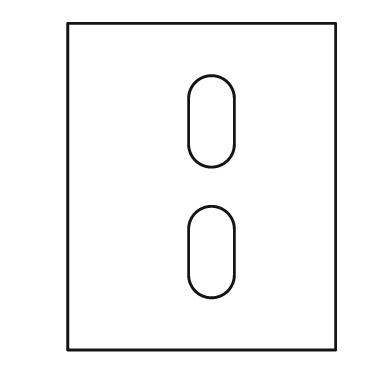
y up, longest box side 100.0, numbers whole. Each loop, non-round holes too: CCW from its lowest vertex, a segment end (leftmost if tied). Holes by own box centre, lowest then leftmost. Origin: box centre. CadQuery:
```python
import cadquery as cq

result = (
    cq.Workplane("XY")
    .moveTo(-41.0, -50.0)
    .lineTo(41.0, -50.0)
    .lineTo(41.0, 50.0)
    .lineTo(-41.0, 50.0)
    .close()
    .moveTo(-4.0, -27.0)
    .threePointArc((3.0, -34.0), (10.0, -27.0))
    .lineTo(10.0, -13.0)
    .threePointArc((3.0, -6.0), (-4.0, -13.0))
    .close()
    .moveTo(-4.0, 13.0)
    .threePointArc((3.0, 6.0), (10.0, 13.0))
    .lineTo(10.0, 27.0)
    .threePointArc((3.0, 34.0), (-4.0, 27.0))
    .close()
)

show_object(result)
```